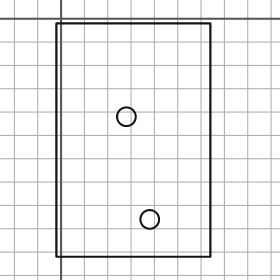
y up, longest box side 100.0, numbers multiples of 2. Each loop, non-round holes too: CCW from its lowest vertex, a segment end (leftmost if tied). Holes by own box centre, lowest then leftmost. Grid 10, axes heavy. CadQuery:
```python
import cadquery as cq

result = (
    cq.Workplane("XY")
    .moveTo(-2.0, -102.0)
    .lineTo(64.0, -102.0)
    .lineTo(64.0, -2.0)
    .lineTo(-2.0, -2.0)
    .close()
    .moveTo(38.0, -86.0)
    .circle(4.0)
    .moveTo(28.0, -42.0)
    .circle(4.0)
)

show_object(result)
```